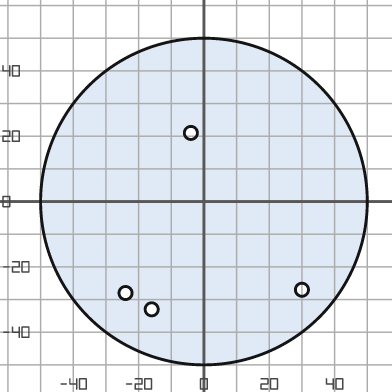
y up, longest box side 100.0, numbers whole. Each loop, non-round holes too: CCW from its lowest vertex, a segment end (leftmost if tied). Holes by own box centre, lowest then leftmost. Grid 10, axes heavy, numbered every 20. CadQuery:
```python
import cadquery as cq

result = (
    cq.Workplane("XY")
    .moveTo(0.0, 0.0)
    .circle(50.0)
    .moveTo(-16.0, -33.0)
    .circle(2.0)
    .moveTo(-24.0, -28.0)
    .circle(2.0)
    .moveTo(30.0, -27.0)
    .circle(2.0)
    .moveTo(-4.0, 21.0)
    .circle(2.0)
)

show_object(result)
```